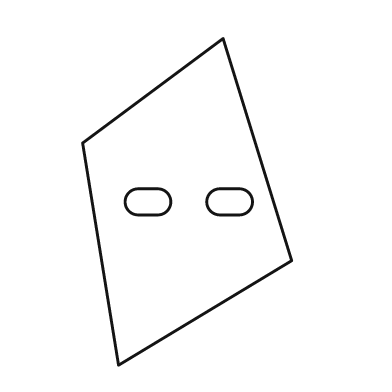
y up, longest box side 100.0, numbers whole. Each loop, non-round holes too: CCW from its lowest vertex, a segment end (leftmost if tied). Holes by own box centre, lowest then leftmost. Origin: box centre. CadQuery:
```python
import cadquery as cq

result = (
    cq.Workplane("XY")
    .moveTo(-21.0, -50.0)
    .lineTo(32.0, -18.0)
    .lineTo(11.0, 50.0)
    .lineTo(-32.0, 18.0)
    .close()
    .moveTo(-15.0, -4.0)
    .lineTo(-9.0, -4.0)
    .threePointArc((-5.0, 0.0), (-9.0, 4.0))
    .lineTo(-15.0, 4.0)
    .threePointArc((-19.0, 0.0), (-15.0, -4.0))
    .close()
    .moveTo(10.0, -4.0)
    .lineTo(16.0, -4.0)
    .threePointArc((20.0, 0.0), (16.0, 4.0))
    .lineTo(10.0, 4.0)
    .threePointArc((6.0, 0.0), (10.0, -4.0))
    .close()
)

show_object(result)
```